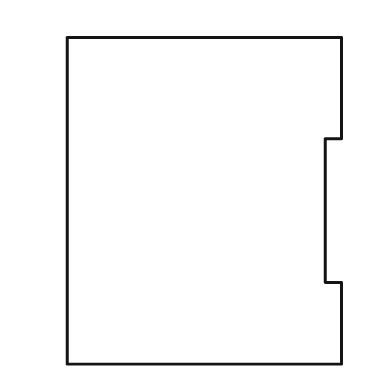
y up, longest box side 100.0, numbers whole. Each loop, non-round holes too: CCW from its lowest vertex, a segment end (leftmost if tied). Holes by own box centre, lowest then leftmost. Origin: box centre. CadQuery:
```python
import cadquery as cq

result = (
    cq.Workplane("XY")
    .moveTo(-42.0, -50.0)
    .lineTo(42.0, -50.0)
    .lineTo(42.0, -25.0)
    .lineTo(37.0, -25.0)
    .lineTo(37.0, 19.0)
    .lineTo(42.0, 19.0)
    .lineTo(42.0, 50.0)
    .lineTo(-42.0, 50.0)
    .close()
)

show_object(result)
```